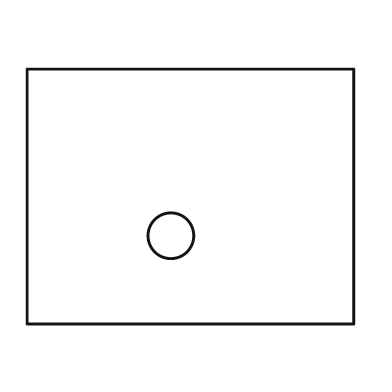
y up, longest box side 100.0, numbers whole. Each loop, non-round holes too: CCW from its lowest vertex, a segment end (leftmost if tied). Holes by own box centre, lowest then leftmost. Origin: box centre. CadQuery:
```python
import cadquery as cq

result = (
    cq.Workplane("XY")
    .moveTo(-50.0, -39.0)
    .lineTo(50.0, -39.0)
    .lineTo(50.0, 39.0)
    .lineTo(-50.0, 39.0)
    .close()
    .moveTo(-6.0, -12.0)
    .circle(7.0)
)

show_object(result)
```